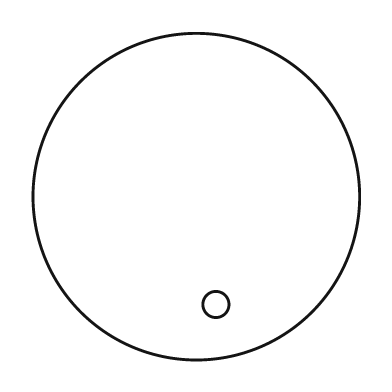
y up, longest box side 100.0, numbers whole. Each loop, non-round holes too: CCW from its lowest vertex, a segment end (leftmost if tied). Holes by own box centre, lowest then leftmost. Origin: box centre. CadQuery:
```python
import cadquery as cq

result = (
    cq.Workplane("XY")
    .moveTo(0.0, 0.0)
    .circle(50.0)
    .moveTo(6.0, -33.0)
    .circle(4.0)
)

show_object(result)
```